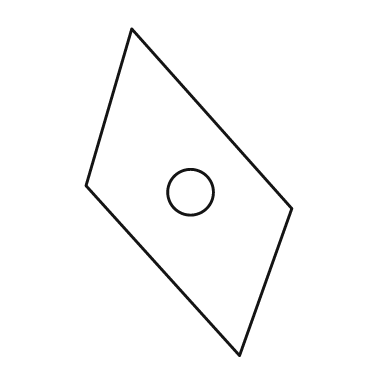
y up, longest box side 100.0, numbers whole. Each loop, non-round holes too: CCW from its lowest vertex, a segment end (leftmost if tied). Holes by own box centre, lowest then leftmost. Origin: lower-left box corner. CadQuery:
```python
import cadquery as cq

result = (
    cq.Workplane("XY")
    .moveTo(47.0, 0.0)
    .lineTo(63.0, 45.0)
    .lineTo(14.0, 100.0)
    .lineTo(0.0, 52.0)
    .close()
    .moveTo(32.0, 50.0)
    .circle(7.0)
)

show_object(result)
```